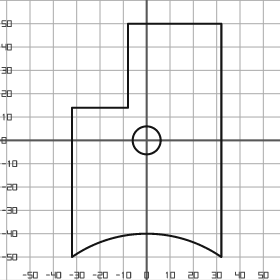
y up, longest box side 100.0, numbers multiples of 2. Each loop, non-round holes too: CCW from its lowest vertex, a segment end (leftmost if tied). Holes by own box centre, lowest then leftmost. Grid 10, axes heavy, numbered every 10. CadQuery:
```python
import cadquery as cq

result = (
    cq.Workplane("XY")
    .moveTo(-32.0, -50.0)
    .threePointArc((0.0, -40.0), (32.0, -50.0))
    .lineTo(32.0, 50.0)
    .lineTo(-8.0, 50.0)
    .lineTo(-8.0, 14.0)
    .lineTo(-32.0, 14.0)
    .close()
    .moveTo(0.0, 0.0)
    .circle(6.0)
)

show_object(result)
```